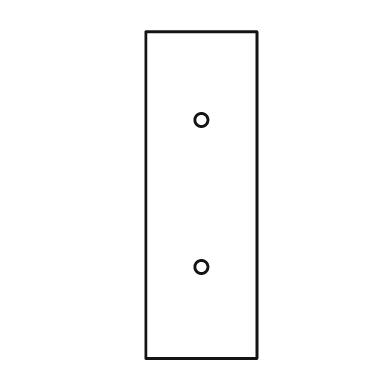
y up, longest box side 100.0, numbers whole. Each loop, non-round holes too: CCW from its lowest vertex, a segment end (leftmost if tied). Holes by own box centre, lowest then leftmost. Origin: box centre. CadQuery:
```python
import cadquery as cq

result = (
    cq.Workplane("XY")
    .moveTo(-17.0, -50.0)
    .lineTo(17.0, -50.0)
    .lineTo(17.0, 50.0)
    .lineTo(-17.0, 50.0)
    .close()
    .moveTo(0.0, -22.0)
    .circle(2.0)
    .moveTo(0.0, 23.0)
    .circle(2.0)
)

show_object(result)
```